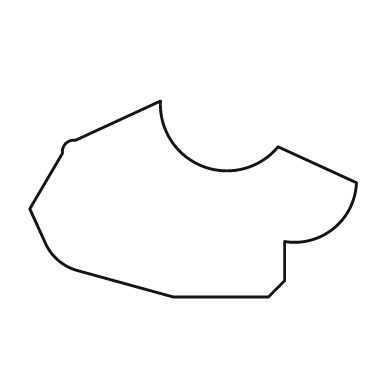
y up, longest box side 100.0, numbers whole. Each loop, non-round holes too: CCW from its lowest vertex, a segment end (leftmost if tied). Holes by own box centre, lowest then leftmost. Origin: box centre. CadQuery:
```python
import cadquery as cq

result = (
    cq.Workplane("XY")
    .moveTo(-6.0, -30.0)
    .lineTo(23.0, -30.0)
    .lineTo(28.0, -25.0)
    .lineTo(28.0, -13.0)
    .threePointArc((43.0, -9.0), (50.0, 5.0))
    .lineTo(26.0, 16.0)
    .threePointArc((3.0, 10.0), (-10.0, 30.0))
    .lineTo(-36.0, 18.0)
    .threePointArc((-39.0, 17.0), (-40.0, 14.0))
    .lineTo(-50.0, -3.0)
    .lineTo(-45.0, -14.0)
    .threePointArc((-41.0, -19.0), (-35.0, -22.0))
    .close()
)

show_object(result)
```